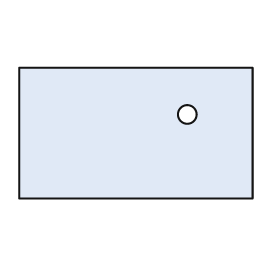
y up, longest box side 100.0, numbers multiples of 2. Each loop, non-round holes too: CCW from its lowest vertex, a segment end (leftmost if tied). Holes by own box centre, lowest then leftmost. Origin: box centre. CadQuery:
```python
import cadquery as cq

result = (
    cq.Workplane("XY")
    .moveTo(-50.0, -28.0)
    .lineTo(50.0, -28.0)
    .lineTo(50.0, 28.0)
    .lineTo(-50.0, 28.0)
    .close()
    .moveTo(22.0, 8.0)
    .circle(4.0)
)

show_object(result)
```